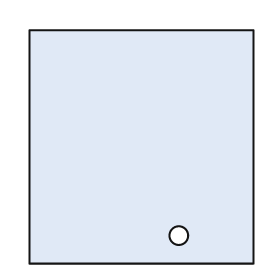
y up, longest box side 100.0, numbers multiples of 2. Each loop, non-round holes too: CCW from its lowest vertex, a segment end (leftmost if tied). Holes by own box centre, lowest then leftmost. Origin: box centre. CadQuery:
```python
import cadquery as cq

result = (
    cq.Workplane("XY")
    .moveTo(-48.0, -50.0)
    .lineTo(48.0, -50.0)
    .lineTo(48.0, 50.0)
    .lineTo(-48.0, 50.0)
    .close()
    .moveTo(16.0, -38.0)
    .circle(4.0)
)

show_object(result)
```